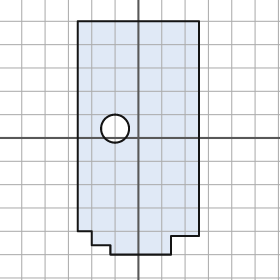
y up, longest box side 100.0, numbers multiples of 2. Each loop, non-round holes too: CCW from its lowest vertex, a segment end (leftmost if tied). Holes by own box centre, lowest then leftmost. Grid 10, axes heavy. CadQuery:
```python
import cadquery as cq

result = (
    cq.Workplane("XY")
    .moveTo(-12.0, -50.0)
    .lineTo(14.0, -50.0)
    .lineTo(14.0, -42.0)
    .lineTo(26.0, -42.0)
    .lineTo(26.0, 50.0)
    .lineTo(-26.0, 50.0)
    .lineTo(-26.0, -40.0)
    .lineTo(-20.0, -40.0)
    .lineTo(-20.0, -46.0)
    .lineTo(-12.0, -46.0)
    .close()
    .moveTo(-10.0, 4.0)
    .circle(6.0)
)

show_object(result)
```